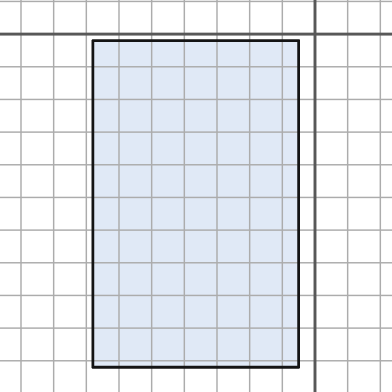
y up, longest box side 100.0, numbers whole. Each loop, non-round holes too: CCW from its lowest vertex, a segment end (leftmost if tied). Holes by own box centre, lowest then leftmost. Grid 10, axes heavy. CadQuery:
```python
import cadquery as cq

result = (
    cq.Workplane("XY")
    .moveTo(-68.0, -102.0)
    .lineTo(-5.0, -102.0)
    .lineTo(-5.0, -2.0)
    .lineTo(-68.0, -2.0)
    .close()
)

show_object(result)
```